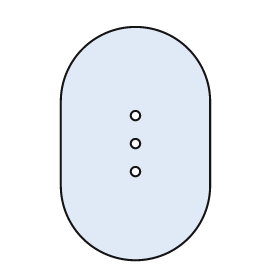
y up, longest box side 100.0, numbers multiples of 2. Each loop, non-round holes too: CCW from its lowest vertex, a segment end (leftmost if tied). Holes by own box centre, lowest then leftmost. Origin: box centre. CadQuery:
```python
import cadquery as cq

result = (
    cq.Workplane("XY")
    .moveTo(-32.0, -18.0)
    .threePointArc((0.0, -50.0), (32.0, -18.0))
    .lineTo(32.0, 18.0)
    .threePointArc((0.0, 50.0), (-32.0, 18.0))
    .close()
    .moveTo(0.0, -12.0)
    .circle(2.0)
    .moveTo(0.0, 0.0)
    .circle(2.0)
    .moveTo(0.0, 12.0)
    .circle(2.0)
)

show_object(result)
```